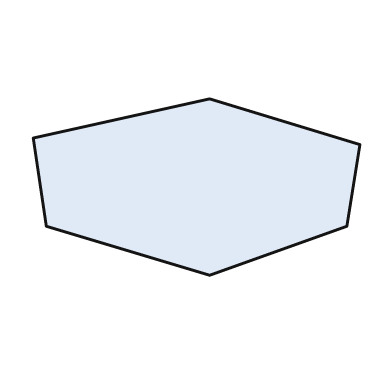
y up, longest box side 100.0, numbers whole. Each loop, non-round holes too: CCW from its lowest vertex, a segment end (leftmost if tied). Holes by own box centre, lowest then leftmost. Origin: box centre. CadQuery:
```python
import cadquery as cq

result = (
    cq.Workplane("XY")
    .moveTo(4.0, -27.0)
    .lineTo(46.0, -12.0)
    .lineTo(50.0, 13.0)
    .lineTo(4.0, 27.0)
    .lineTo(-50.0, 15.0)
    .lineTo(-46.0, -12.0)
    .close()
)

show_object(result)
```